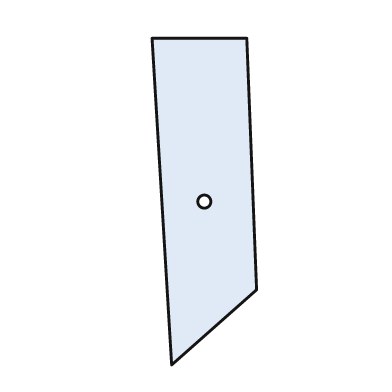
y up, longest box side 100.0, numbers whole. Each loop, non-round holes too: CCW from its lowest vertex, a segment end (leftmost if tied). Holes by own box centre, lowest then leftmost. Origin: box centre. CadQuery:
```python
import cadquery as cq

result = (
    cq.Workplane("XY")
    .moveTo(-10.0, -50.0)
    .lineTo(16.0, -27.0)
    .lineTo(13.0, 50.0)
    .lineTo(-16.0, 50.0)
    .close()
    .moveTo(0.0, 0.0)
    .circle(2.0)
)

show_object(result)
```